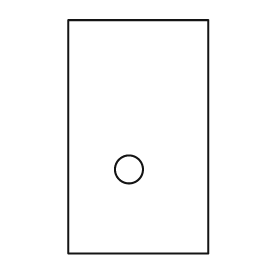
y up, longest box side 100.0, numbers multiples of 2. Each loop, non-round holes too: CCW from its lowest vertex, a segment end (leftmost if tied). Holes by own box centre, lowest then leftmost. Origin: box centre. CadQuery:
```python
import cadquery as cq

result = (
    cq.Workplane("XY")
    .moveTo(-30.0, -50.0)
    .lineTo(30.0, -50.0)
    .lineTo(30.0, 50.0)
    .lineTo(-30.0, 50.0)
    .close()
    .moveTo(-4.0, -14.0)
    .circle(6.0)
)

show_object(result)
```